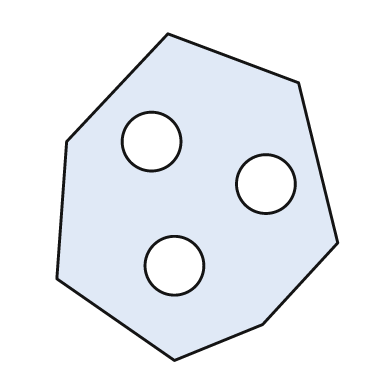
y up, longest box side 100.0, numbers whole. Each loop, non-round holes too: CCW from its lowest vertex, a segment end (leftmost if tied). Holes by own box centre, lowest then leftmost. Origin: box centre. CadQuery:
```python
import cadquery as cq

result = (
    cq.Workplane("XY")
    .moveTo(-7.0, -50.0)
    .lineTo(20.0, -39.0)
    .lineTo(43.0, -14.0)
    .lineTo(31.0, 35.0)
    .lineTo(-9.0, 50.0)
    .lineTo(-40.0, 17.0)
    .lineTo(-43.0, -25.0)
    .close()
    .moveTo(-7.0, -21.0)
    .circle(9.0)
    .moveTo(21.0, 4.0)
    .circle(9.0)
    .moveTo(-14.0, 17.0)
    .circle(9.0)
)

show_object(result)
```